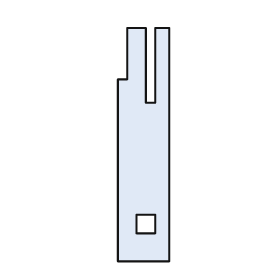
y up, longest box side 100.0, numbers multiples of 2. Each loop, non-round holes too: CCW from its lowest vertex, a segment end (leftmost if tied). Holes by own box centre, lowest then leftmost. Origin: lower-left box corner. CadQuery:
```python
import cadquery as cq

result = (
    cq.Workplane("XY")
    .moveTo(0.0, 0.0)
    .lineTo(22.0, 0.0)
    .lineTo(22.0, 100.0)
    .lineTo(16.0, 100.0)
    .lineTo(16.0, 68.0)
    .lineTo(12.0, 68.0)
    .lineTo(12.0, 100.0)
    .lineTo(4.0, 100.0)
    .lineTo(4.0, 78.0)
    .lineTo(0.0, 78.0)
    .close()
    .moveTo(8.0, 12.0)
    .lineTo(16.0, 12.0)
    .lineTo(16.0, 20.0)
    .lineTo(8.0, 20.0)
    .close()
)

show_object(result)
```